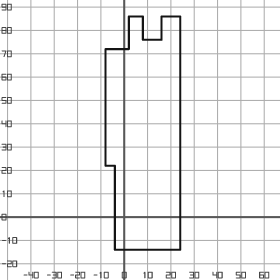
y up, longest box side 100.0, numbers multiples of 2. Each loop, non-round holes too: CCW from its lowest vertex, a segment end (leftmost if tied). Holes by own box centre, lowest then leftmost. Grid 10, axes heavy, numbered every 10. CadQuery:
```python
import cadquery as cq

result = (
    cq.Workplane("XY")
    .moveTo(-4.0, -14.0)
    .lineTo(24.0, -14.0)
    .lineTo(24.0, 86.0)
    .lineTo(16.0, 86.0)
    .lineTo(16.0, 76.0)
    .lineTo(8.0, 76.0)
    .lineTo(8.0, 86.0)
    .lineTo(2.0, 86.0)
    .lineTo(2.0, 72.0)
    .lineTo(-8.0, 72.0)
    .lineTo(-8.0, 22.0)
    .lineTo(-4.0, 22.0)
    .close()
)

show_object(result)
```